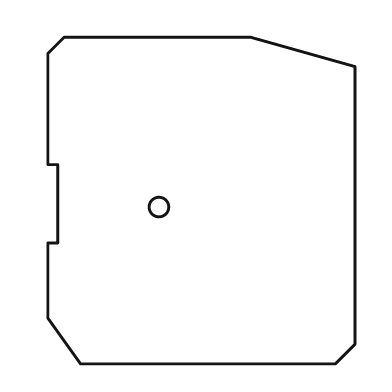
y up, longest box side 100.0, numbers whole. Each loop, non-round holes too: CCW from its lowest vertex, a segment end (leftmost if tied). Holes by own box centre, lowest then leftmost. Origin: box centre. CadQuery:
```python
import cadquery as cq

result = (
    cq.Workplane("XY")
    .moveTo(-37.0, -50.0)
    .lineTo(41.0, -50.0)
    .lineTo(47.0, -44.0)
    .lineTo(47.0, 41.0)
    .lineTo(15.0, 50.0)
    .lineTo(-42.0, 50.0)
    .lineTo(-47.0, 45.0)
    .lineTo(-47.0, 11.0)
    .lineTo(-44.0, 11.0)
    .lineTo(-44.0, -13.0)
    .lineTo(-47.0, -13.0)
    .lineTo(-47.0, -36.0)
    .close()
    .moveTo(-13.0, -2.0)
    .circle(3.0)
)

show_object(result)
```